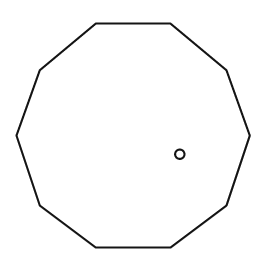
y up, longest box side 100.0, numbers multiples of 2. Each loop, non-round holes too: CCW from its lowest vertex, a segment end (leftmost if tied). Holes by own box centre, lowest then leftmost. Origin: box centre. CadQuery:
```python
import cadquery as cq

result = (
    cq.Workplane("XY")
    .moveTo(-16.0, -48.0)
    .lineTo(16.0, -48.0)
    .lineTo(40.0, -30.0)
    .lineTo(50.0, 0.0)
    .lineTo(40.0, 28.0)
    .lineTo(16.0, 48.0)
    .lineTo(-16.0, 48.0)
    .lineTo(-40.0, 28.0)
    .lineTo(-50.0, 0.0)
    .lineTo(-40.0, -30.0)
    .close()
    .moveTo(20.0, -8.0)
    .circle(2.0)
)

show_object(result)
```